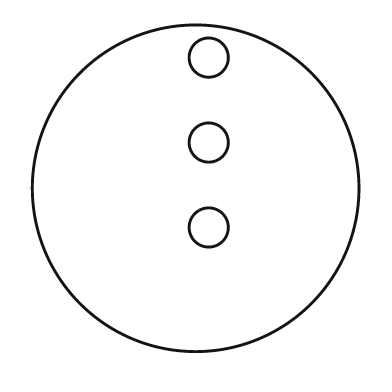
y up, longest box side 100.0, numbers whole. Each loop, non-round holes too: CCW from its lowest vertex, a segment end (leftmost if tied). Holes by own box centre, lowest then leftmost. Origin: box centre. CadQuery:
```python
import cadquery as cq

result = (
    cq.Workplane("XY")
    .moveTo(0.0, 0.0)
    .circle(50.0)
    .moveTo(4.0, -12.0)
    .circle(6.0)
    .moveTo(4.0, 14.0)
    .circle(6.0)
    .moveTo(4.0, 40.0)
    .circle(6.0)
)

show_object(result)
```